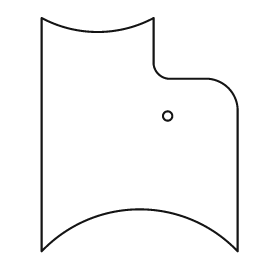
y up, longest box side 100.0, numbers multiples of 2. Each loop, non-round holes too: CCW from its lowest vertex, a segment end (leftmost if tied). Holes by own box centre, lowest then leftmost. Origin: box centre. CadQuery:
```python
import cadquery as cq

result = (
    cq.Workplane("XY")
    .moveTo(-42.0, -50.0)
    .threePointArc((0.0, -32.0), (42.0, -50.0))
    .lineTo(42.0, 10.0)
    .threePointArc((38.0, 20.0), (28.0, 24.0))
    .lineTo(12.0, 24.0)
    .threePointArc((8.0, 26.0), (6.0, 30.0))
    .lineTo(6.0, 50.0)
    .threePointArc((-18.0, 44.0), (-42.0, 50.0))
    .close()
    .moveTo(12.0, 8.0)
    .circle(2.0)
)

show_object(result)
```